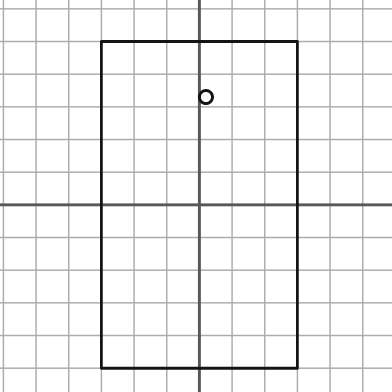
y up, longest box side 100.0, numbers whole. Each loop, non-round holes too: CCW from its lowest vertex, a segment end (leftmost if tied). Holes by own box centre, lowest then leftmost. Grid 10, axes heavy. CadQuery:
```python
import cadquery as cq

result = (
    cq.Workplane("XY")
    .moveTo(-30.0, -50.0)
    .lineTo(30.0, -50.0)
    .lineTo(30.0, 50.0)
    .lineTo(-30.0, 50.0)
    .close()
    .moveTo(2.0, 33.0)
    .circle(2.0)
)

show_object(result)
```